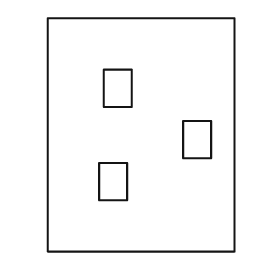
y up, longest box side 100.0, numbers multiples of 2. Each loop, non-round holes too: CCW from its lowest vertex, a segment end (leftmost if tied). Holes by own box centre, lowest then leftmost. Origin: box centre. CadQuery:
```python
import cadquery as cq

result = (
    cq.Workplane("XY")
    .moveTo(-40.0, -50.0)
    .lineTo(40.0, -50.0)
    .lineTo(40.0, 50.0)
    .lineTo(-40.0, 50.0)
    .close()
    .moveTo(-18.0, -28.0)
    .lineTo(-6.0, -28.0)
    .lineTo(-6.0, -12.0)
    .lineTo(-18.0, -12.0)
    .close()
    .moveTo(18.0, -10.0)
    .lineTo(30.0, -10.0)
    .lineTo(30.0, 6.0)
    .lineTo(18.0, 6.0)
    .close()
    .moveTo(-16.0, 12.0)
    .lineTo(-4.0, 12.0)
    .lineTo(-4.0, 28.0)
    .lineTo(-16.0, 28.0)
    .close()
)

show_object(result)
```